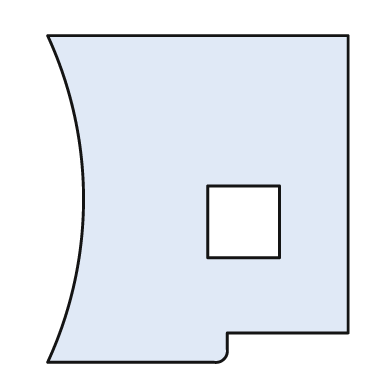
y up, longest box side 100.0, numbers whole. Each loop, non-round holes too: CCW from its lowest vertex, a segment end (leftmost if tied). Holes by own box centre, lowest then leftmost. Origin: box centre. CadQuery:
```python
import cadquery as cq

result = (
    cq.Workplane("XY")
    .moveTo(-46.0, -50.0)
    .lineTo(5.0, -50.0)
    .threePointArc((8.0, -49.0), (9.0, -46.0))
    .lineTo(9.0, -41.0)
    .lineTo(46.0, -41.0)
    .lineTo(46.0, 50.0)
    .lineTo(-46.0, 50.0)
    .threePointArc((-35.0, 0.0), (-46.0, -50.0))
    .close()
    .moveTo(3.0, -18.0)
    .lineTo(25.0, -18.0)
    .lineTo(25.0, 4.0)
    .lineTo(3.0, 4.0)
    .close()
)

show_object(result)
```